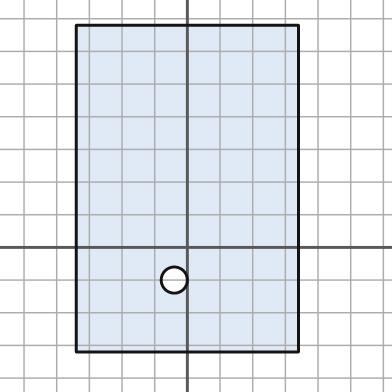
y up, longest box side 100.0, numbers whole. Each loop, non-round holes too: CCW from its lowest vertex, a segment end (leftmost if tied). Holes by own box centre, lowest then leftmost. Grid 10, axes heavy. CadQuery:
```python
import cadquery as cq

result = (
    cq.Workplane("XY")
    .moveTo(-34.0, -32.0)
    .lineTo(34.0, -32.0)
    .lineTo(34.0, 68.0)
    .lineTo(-34.0, 68.0)
    .close()
    .moveTo(-4.0, -10.0)
    .circle(4.0)
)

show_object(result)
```